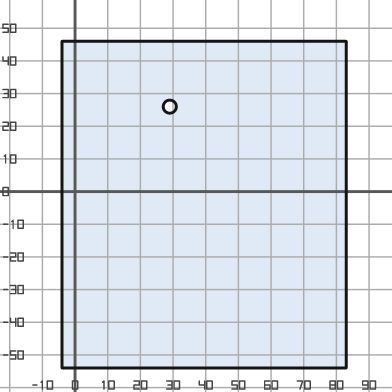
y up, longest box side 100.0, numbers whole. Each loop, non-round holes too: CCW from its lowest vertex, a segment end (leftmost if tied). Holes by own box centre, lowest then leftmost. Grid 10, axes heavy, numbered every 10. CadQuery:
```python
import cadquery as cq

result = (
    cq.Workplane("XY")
    .moveTo(-4.0, -54.0)
    .lineTo(83.0, -54.0)
    .lineTo(83.0, 46.0)
    .lineTo(-4.0, 46.0)
    .close()
    .moveTo(29.0, 26.0)
    .circle(2.0)
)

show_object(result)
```